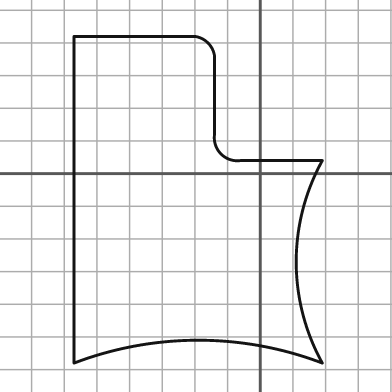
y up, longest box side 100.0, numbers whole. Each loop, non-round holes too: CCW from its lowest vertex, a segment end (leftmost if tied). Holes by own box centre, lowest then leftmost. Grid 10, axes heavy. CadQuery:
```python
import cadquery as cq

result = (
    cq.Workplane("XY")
    .moveTo(-57.0, -58.0)
    .threePointArc((-19.0, -51.0), (19.0, -58.0))
    .threePointArc((11.0, -27.0), (19.0, 4.0))
    .lineTo(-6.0, 4.0)
    .threePointArc((-12.0, 6.0), (-14.0, 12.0))
    .lineTo(-14.0, 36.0)
    .threePointArc((-16.0, 40.0), (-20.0, 42.0))
    .lineTo(-57.0, 42.0)
    .close()
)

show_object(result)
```